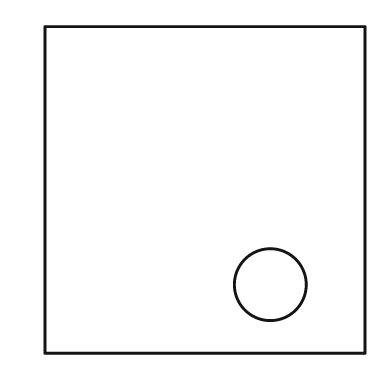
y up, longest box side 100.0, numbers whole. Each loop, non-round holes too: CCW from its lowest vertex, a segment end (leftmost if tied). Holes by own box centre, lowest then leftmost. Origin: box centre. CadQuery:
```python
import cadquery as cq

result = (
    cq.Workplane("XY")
    .moveTo(-49.0, -50.0)
    .lineTo(49.0, -50.0)
    .lineTo(49.0, 50.0)
    .lineTo(-49.0, 50.0)
    .close()
    .moveTo(20.0, -29.0)
    .circle(11.0)
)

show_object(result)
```